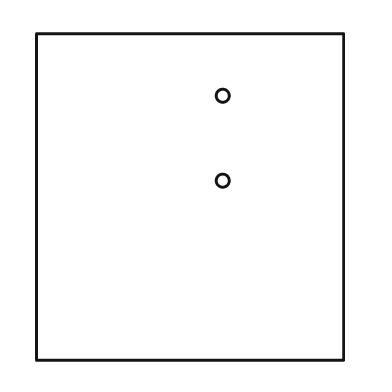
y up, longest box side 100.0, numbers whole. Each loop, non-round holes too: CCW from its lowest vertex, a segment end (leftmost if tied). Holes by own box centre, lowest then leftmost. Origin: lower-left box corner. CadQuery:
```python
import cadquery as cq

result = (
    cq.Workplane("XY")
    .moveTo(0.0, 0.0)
    .lineTo(94.0, 0.0)
    .lineTo(94.0, 100.0)
    .lineTo(0.0, 100.0)
    .close()
    .moveTo(57.0, 55.0)
    .circle(2.0)
    .moveTo(57.0, 81.0)
    .circle(2.0)
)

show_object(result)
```